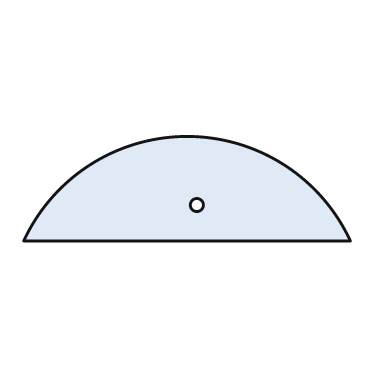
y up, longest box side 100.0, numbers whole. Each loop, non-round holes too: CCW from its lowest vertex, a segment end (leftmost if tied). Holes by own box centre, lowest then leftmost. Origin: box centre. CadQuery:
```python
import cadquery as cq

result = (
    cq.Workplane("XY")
    .moveTo(-50.0, -16.0)
    .lineTo(50.0, -16.0)
    .threePointArc((0.0, 16.0), (-50.0, -16.0))
    .close()
    .moveTo(3.0, -5.0)
    .circle(2.0)
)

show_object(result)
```